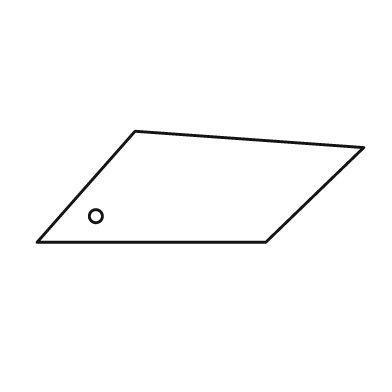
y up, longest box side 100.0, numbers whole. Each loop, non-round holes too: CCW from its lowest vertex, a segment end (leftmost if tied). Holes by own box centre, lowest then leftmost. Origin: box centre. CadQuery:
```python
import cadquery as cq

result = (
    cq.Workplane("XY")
    .moveTo(-50.0, -17.0)
    .lineTo(20.0, -17.0)
    .lineTo(50.0, 12.0)
    .lineTo(-20.0, 17.0)
    .close()
    .moveTo(-32.0, -9.0)
    .circle(2.0)
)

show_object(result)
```